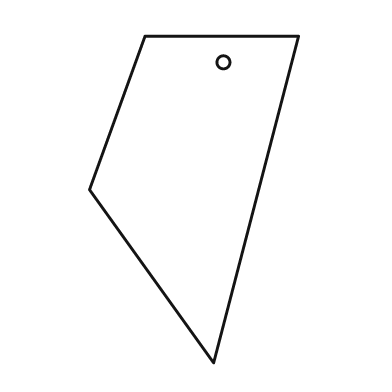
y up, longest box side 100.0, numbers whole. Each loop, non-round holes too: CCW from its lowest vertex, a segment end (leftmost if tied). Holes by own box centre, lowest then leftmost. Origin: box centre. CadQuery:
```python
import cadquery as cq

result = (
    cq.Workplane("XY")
    .moveTo(6.0, -50.0)
    .lineTo(32.0, 50.0)
    .lineTo(-15.0, 50.0)
    .lineTo(-32.0, 3.0)
    .close()
    .moveTo(9.0, 42.0)
    .circle(2.0)
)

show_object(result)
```